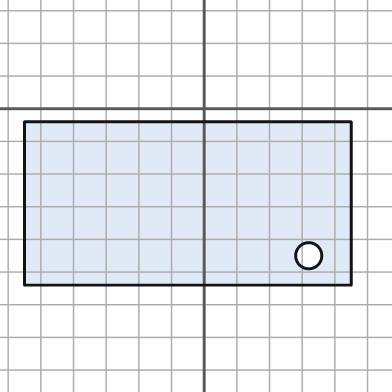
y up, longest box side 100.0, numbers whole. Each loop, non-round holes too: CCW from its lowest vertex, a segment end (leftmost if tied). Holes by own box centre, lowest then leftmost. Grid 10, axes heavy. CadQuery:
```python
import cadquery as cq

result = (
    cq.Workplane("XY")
    .moveTo(-55.0, -54.0)
    .lineTo(45.0, -54.0)
    .lineTo(45.0, -4.0)
    .lineTo(-55.0, -4.0)
    .close()
    .moveTo(32.0, -45.0)
    .circle(4.0)
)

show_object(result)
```